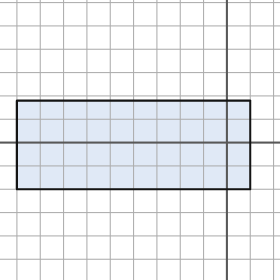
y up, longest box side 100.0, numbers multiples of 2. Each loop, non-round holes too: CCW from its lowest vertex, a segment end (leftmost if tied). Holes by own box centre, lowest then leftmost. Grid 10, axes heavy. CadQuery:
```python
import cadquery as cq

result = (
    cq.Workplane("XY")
    .moveTo(-90.0, -20.0)
    .lineTo(10.0, -20.0)
    .lineTo(10.0, 18.0)
    .lineTo(-90.0, 18.0)
    .close()
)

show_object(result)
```